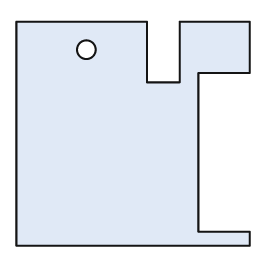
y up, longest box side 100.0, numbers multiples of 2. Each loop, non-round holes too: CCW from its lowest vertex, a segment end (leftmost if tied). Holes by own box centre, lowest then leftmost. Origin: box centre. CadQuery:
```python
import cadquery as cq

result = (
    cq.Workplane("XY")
    .moveTo(-50.0, -48.0)
    .lineTo(50.0, -48.0)
    .lineTo(50.0, -42.0)
    .lineTo(28.0, -42.0)
    .lineTo(28.0, 26.0)
    .lineTo(50.0, 26.0)
    .lineTo(50.0, 48.0)
    .lineTo(20.0, 48.0)
    .lineTo(20.0, 22.0)
    .lineTo(6.0, 22.0)
    .lineTo(6.0, 48.0)
    .lineTo(-50.0, 48.0)
    .close()
    .moveTo(-20.0, 36.0)
    .circle(4.0)
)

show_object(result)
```